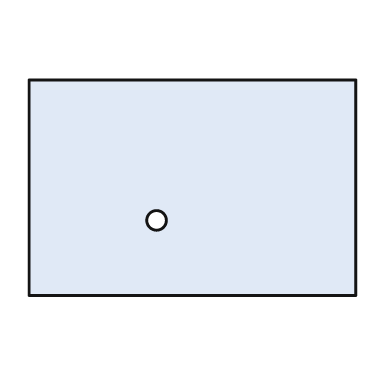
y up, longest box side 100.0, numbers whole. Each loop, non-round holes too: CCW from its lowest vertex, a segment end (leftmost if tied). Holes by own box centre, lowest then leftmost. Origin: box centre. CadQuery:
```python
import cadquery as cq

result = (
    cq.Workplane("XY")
    .moveTo(-50.0, -33.0)
    .lineTo(50.0, -33.0)
    .lineTo(50.0, 33.0)
    .lineTo(-50.0, 33.0)
    .close()
    .moveTo(-11.0, -10.0)
    .circle(3.0)
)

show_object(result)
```